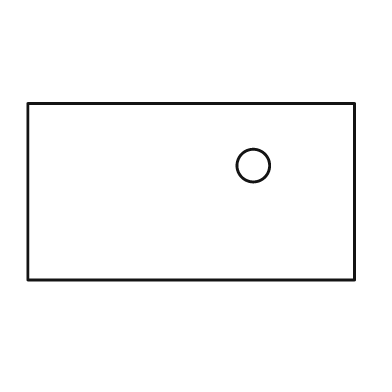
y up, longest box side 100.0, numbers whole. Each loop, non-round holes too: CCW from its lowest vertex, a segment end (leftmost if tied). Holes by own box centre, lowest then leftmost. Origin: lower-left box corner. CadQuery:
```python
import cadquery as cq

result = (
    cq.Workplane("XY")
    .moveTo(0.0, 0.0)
    .lineTo(100.0, 0.0)
    .lineTo(100.0, 54.0)
    .lineTo(0.0, 54.0)
    .close()
    .moveTo(69.0, 35.0)
    .circle(5.0)
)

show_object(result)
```